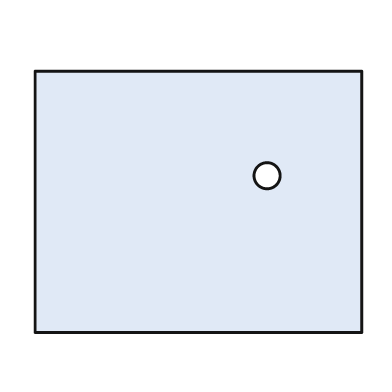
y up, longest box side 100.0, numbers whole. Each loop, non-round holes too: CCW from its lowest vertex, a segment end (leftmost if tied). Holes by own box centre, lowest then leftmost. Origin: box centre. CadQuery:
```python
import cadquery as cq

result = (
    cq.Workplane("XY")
    .moveTo(-50.0, -40.0)
    .lineTo(50.0, -40.0)
    .lineTo(50.0, 40.0)
    .lineTo(-50.0, 40.0)
    .close()
    .moveTo(21.0, 8.0)
    .circle(4.0)
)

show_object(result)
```